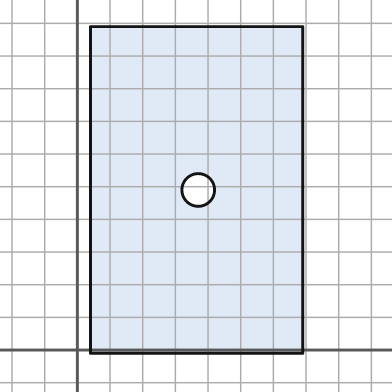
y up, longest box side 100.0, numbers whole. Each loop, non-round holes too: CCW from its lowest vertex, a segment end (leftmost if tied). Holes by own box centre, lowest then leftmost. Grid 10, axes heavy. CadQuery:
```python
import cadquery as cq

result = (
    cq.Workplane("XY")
    .moveTo(4.0, -1.0)
    .lineTo(69.0, -1.0)
    .lineTo(69.0, 99.0)
    .lineTo(4.0, 99.0)
    .close()
    .moveTo(37.0, 49.0)
    .circle(5.0)
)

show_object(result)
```